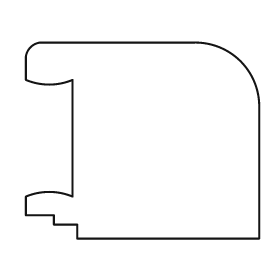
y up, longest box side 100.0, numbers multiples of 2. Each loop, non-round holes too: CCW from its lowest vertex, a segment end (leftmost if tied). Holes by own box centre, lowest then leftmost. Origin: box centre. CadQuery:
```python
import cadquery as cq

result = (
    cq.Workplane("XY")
    .moveTo(-28.0, -42.0)
    .lineTo(50.0, -42.0)
    .lineTo(50.0, 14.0)
    .threePointArc((42.0, 34.0), (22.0, 42.0))
    .lineTo(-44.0, 42.0)
    .threePointArc((-48.0, 40.0), (-50.0, 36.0))
    .lineTo(-50.0, 26.0)
    .threePointArc((-40.0, 24.0), (-30.0, 26.0))
    .lineTo(-30.0, -24.0)
    .threePointArc((-40.0, -22.0), (-50.0, -24.0))
    .lineTo(-50.0, -32.0)
    .lineTo(-38.0, -32.0)
    .lineTo(-38.0, -36.0)
    .lineTo(-28.0, -36.0)
    .close()
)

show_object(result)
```